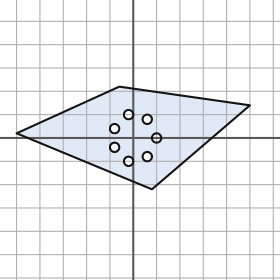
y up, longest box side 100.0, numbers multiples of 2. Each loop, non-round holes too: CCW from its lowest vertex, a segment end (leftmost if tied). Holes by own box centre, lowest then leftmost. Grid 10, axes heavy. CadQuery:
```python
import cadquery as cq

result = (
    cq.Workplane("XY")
    .moveTo(8.0, -22.0)
    .lineTo(50.0, 14.0)
    .lineTo(-6.0, 22.0)
    .lineTo(-50.0, 2.0)
    .close()
    .moveTo(-2.0, -10.0)
    .circle(2.0)
    .moveTo(6.0, -8.0)
    .circle(2.0)
    .moveTo(-8.0, -4.0)
    .circle(2.0)
    .moveTo(10.0, 0.0)
    .circle(2.0)
    .moveTo(-8.0, 4.0)
    .circle(2.0)
    .moveTo(6.0, 8.0)
    .circle(2.0)
    .moveTo(-2.0, 10.0)
    .circle(2.0)
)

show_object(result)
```